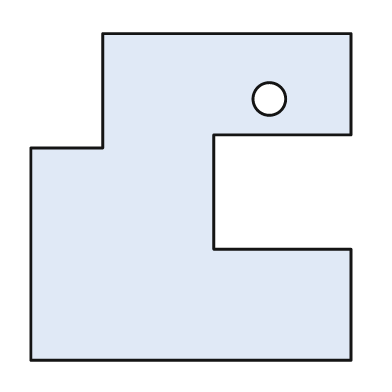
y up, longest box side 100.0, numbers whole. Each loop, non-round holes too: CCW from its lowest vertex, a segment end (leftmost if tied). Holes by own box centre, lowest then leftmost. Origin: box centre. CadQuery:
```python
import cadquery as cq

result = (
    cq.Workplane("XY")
    .moveTo(-49.0, -50.0)
    .lineTo(49.0, -50.0)
    .lineTo(49.0, -16.0)
    .lineTo(7.0, -16.0)
    .lineTo(7.0, 19.0)
    .lineTo(49.0, 19.0)
    .lineTo(49.0, 50.0)
    .lineTo(-27.0, 50.0)
    .lineTo(-27.0, 15.0)
    .lineTo(-49.0, 15.0)
    .close()
    .moveTo(24.0, 30.0)
    .circle(5.0)
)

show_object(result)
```